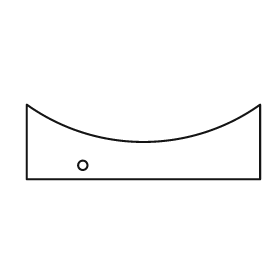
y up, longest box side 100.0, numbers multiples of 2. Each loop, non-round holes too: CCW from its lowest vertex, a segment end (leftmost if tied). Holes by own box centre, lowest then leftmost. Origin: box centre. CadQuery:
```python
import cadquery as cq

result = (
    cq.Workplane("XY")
    .moveTo(-50.0, -16.0)
    .lineTo(50.0, -16.0)
    .lineTo(50.0, 16.0)
    .threePointArc((0.0, 0.0), (-50.0, 16.0))
    .close()
    .moveTo(-26.0, -10.0)
    .circle(2.0)
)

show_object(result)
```